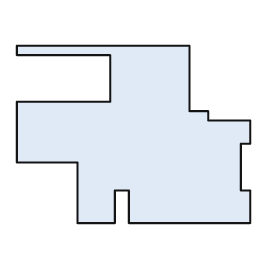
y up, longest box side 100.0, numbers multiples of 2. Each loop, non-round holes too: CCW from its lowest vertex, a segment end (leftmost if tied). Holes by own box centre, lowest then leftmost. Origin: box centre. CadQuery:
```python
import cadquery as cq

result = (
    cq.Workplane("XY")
    .moveTo(-24.0, -38.0)
    .lineTo(-8.0, -38.0)
    .lineTo(-8.0, -24.0)
    .lineTo(-2.0, -24.0)
    .lineTo(-2.0, -38.0)
    .lineTo(50.0, -38.0)
    .lineTo(50.0, -24.0)
    .lineTo(46.0, -24.0)
    .lineTo(46.0, -4.0)
    .lineTo(50.0, -4.0)
    .lineTo(50.0, 6.0)
    .lineTo(32.0, 6.0)
    .lineTo(32.0, 10.0)
    .lineTo(24.0, 10.0)
    .lineTo(24.0, 38.0)
    .lineTo(-50.0, 38.0)
    .lineTo(-50.0, 34.0)
    .lineTo(-10.0, 34.0)
    .lineTo(-10.0, 14.0)
    .lineTo(-50.0, 14.0)
    .lineTo(-50.0, -12.0)
    .lineTo(-24.0, -12.0)
    .close()
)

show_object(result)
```